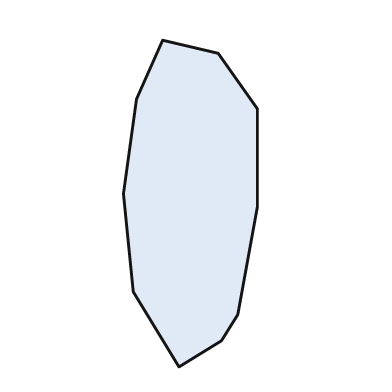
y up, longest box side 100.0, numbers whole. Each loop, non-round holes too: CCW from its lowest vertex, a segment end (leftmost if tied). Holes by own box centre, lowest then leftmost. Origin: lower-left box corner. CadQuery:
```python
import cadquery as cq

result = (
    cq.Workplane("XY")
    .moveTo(17.0, 0.0)
    .lineTo(30.0, 8.0)
    .lineTo(35.0, 16.0)
    .lineTo(41.0, 49.0)
    .lineTo(41.0, 79.0)
    .lineTo(29.0, 96.0)
    .lineTo(12.0, 100.0)
    .lineTo(4.0, 82.0)
    .lineTo(0.0, 53.0)
    .lineTo(3.0, 23.0)
    .close()
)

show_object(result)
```